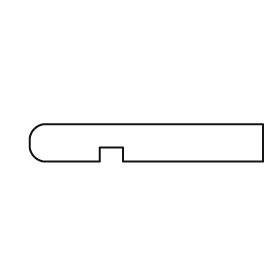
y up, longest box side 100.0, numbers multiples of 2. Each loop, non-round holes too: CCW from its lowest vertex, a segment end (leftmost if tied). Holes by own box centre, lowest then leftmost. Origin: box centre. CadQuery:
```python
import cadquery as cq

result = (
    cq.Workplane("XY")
    .moveTo(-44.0, -8.0)
    .lineTo(-20.0, -8.0)
    .lineTo(-20.0, -2.0)
    .lineTo(-10.0, -2.0)
    .lineTo(-10.0, -8.0)
    .lineTo(50.0, -8.0)
    .lineTo(50.0, 8.0)
    .lineTo(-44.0, 8.0)
    .threePointArc((-48.0, 6.0), (-50.0, 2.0))
    .lineTo(-50.0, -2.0)
    .threePointArc((-48.0, -6.0), (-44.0, -8.0))
    .close()
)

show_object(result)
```